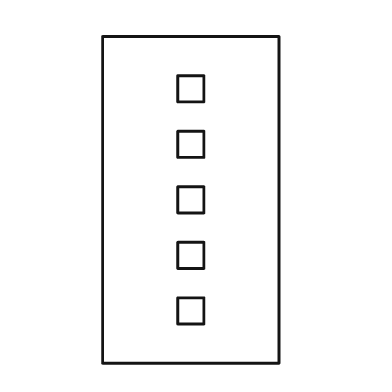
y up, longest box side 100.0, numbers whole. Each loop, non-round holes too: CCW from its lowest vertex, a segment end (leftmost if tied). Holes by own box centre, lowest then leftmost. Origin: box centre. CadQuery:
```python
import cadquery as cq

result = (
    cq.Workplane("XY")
    .moveTo(-27.0, -50.0)
    .lineTo(27.0, -50.0)
    .lineTo(27.0, 50.0)
    .lineTo(-27.0, 50.0)
    .close()
    .moveTo(-4.0, -38.0)
    .lineTo(4.0, -38.0)
    .lineTo(4.0, -30.0)
    .lineTo(-4.0, -30.0)
    .close()
    .moveTo(-4.0, -21.0)
    .lineTo(4.0, -21.0)
    .lineTo(4.0, -13.0)
    .lineTo(-4.0, -13.0)
    .close()
    .moveTo(-4.0, -4.0)
    .lineTo(4.0, -4.0)
    .lineTo(4.0, 4.0)
    .lineTo(-4.0, 4.0)
    .close()
    .moveTo(-4.0, 13.0)
    .lineTo(4.0, 13.0)
    .lineTo(4.0, 21.0)
    .lineTo(-4.0, 21.0)
    .close()
    .moveTo(-4.0, 30.0)
    .lineTo(4.0, 30.0)
    .lineTo(4.0, 38.0)
    .lineTo(-4.0, 38.0)
    .close()
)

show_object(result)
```